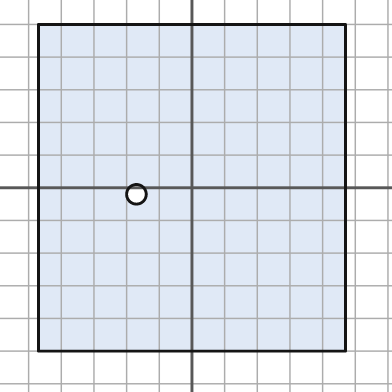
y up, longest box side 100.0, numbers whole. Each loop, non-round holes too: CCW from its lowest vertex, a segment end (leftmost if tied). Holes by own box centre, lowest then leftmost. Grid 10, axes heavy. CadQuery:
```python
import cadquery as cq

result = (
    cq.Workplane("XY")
    .moveTo(-47.0, -50.0)
    .lineTo(47.0, -50.0)
    .lineTo(47.0, 50.0)
    .lineTo(-47.0, 50.0)
    .close()
    .moveTo(-17.0, -2.0)
    .circle(3.0)
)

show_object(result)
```